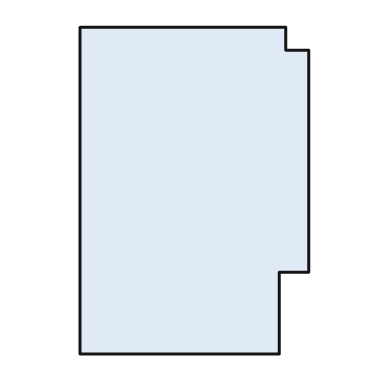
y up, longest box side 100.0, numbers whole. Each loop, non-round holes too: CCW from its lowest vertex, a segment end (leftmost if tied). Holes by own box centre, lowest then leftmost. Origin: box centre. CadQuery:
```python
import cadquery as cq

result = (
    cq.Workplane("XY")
    .moveTo(-35.0, -50.0)
    .lineTo(26.0, -50.0)
    .lineTo(26.0, -25.0)
    .lineTo(35.0, -25.0)
    .lineTo(35.0, 43.0)
    .lineTo(28.0, 43.0)
    .lineTo(28.0, 50.0)
    .lineTo(-35.0, 50.0)
    .close()
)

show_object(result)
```